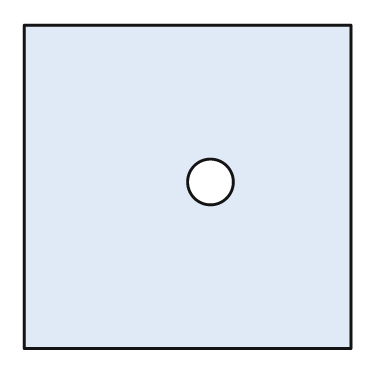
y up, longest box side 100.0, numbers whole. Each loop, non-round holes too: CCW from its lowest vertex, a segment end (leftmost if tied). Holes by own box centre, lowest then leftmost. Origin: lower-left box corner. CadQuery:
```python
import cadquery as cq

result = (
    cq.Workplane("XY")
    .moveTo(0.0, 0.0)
    .lineTo(100.0, 0.0)
    .lineTo(100.0, 99.0)
    .lineTo(0.0, 99.0)
    .close()
    .moveTo(57.0, 51.0)
    .circle(7.0)
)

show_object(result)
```